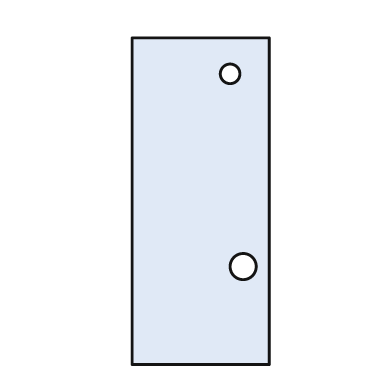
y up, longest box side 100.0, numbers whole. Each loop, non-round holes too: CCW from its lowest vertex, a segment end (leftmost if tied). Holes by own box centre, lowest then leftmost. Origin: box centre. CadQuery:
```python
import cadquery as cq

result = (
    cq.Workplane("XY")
    .moveTo(-21.0, -50.0)
    .lineTo(21.0, -50.0)
    .lineTo(21.0, 50.0)
    .lineTo(-21.0, 50.0)
    .close()
    .moveTo(13.0, -20.0)
    .circle(4.0)
    .moveTo(9.0, 39.0)
    .circle(3.0)
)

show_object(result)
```